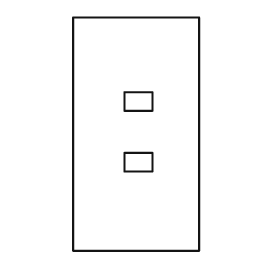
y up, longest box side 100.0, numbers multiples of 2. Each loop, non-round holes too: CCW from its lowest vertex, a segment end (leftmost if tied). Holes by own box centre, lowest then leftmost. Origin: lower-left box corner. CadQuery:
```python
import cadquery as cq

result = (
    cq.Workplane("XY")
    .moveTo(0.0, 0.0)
    .lineTo(54.0, 0.0)
    .lineTo(54.0, 100.0)
    .lineTo(0.0, 100.0)
    .close()
    .moveTo(22.0, 34.0)
    .lineTo(34.0, 34.0)
    .lineTo(34.0, 42.0)
    .lineTo(22.0, 42.0)
    .close()
    .moveTo(22.0, 60.0)
    .lineTo(34.0, 60.0)
    .lineTo(34.0, 68.0)
    .lineTo(22.0, 68.0)
    .close()
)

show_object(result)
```